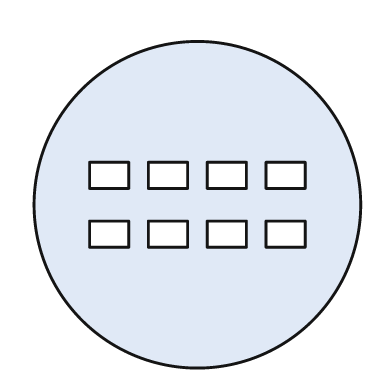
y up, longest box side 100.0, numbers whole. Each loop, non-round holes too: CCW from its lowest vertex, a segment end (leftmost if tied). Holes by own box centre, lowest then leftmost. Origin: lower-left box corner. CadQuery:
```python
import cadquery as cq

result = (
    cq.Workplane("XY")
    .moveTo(50.0, 50.0)
    .circle(50.0)
    .moveTo(17.0, 37.0)
    .lineTo(29.0, 37.0)
    .lineTo(29.0, 45.0)
    .lineTo(17.0, 45.0)
    .close()
    .moveTo(35.0, 37.0)
    .lineTo(47.0, 37.0)
    .lineTo(47.0, 45.0)
    .lineTo(35.0, 45.0)
    .close()
    .moveTo(53.0, 37.0)
    .lineTo(65.0, 37.0)
    .lineTo(65.0, 45.0)
    .lineTo(53.0, 45.0)
    .close()
    .moveTo(71.0, 37.0)
    .lineTo(83.0, 37.0)
    .lineTo(83.0, 45.0)
    .lineTo(71.0, 45.0)
    .close()
    .moveTo(17.0, 55.0)
    .lineTo(29.0, 55.0)
    .lineTo(29.0, 63.0)
    .lineTo(17.0, 63.0)
    .close()
    .moveTo(35.0, 55.0)
    .lineTo(47.0, 55.0)
    .lineTo(47.0, 63.0)
    .lineTo(35.0, 63.0)
    .close()
    .moveTo(53.0, 55.0)
    .lineTo(65.0, 55.0)
    .lineTo(65.0, 63.0)
    .lineTo(53.0, 63.0)
    .close()
    .moveTo(71.0, 55.0)
    .lineTo(83.0, 55.0)
    .lineTo(83.0, 63.0)
    .lineTo(71.0, 63.0)
    .close()
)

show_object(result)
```